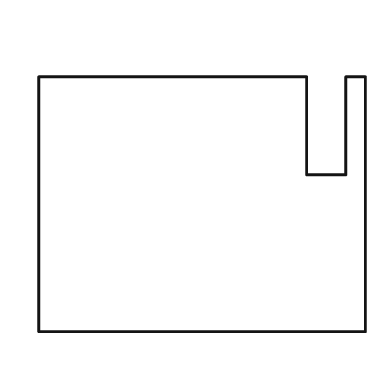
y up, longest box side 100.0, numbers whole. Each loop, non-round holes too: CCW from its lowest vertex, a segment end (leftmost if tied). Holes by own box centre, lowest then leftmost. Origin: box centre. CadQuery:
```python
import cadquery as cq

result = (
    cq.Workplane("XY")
    .moveTo(-50.0, -39.0)
    .lineTo(50.0, -39.0)
    .lineTo(50.0, 39.0)
    .lineTo(44.0, 39.0)
    .lineTo(44.0, 9.0)
    .lineTo(32.0, 9.0)
    .lineTo(32.0, 39.0)
    .lineTo(-50.0, 39.0)
    .close()
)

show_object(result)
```